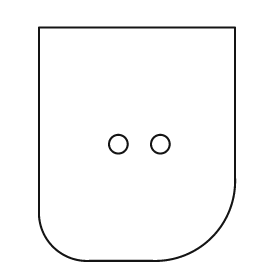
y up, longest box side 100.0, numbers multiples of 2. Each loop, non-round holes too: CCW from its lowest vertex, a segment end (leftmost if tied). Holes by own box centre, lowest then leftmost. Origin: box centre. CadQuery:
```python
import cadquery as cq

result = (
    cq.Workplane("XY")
    .moveTo(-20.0, -50.0)
    .lineTo(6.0, -50.0)
    .threePointArc((32.0, -40.0), (42.0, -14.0))
    .lineTo(42.0, 50.0)
    .lineTo(-42.0, 50.0)
    .lineTo(-42.0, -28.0)
    .threePointArc((-36.0, -44.0), (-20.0, -50.0))
    .close()
    .moveTo(-8.0, 0.0)
    .circle(4.0)
    .moveTo(10.0, 0.0)
    .circle(4.0)
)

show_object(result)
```